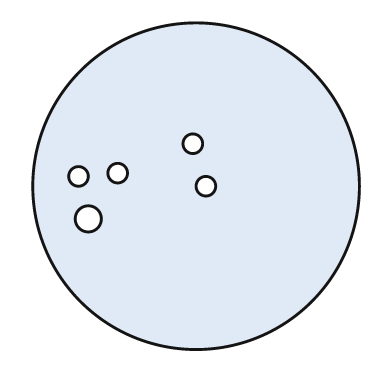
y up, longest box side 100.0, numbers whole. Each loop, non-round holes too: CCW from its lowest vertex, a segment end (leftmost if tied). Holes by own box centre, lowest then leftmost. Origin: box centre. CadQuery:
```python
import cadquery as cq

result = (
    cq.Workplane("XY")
    .moveTo(0.0, 0.0)
    .circle(50.0)
    .moveTo(-33.0, -10.0)
    .circle(4.0)
    .moveTo(3.0, 0.0)
    .circle(3.0)
    .moveTo(-36.0, 3.0)
    .circle(3.0)
    .moveTo(-24.0, 4.0)
    .circle(3.0)
    .moveTo(-1.0, 13.0)
    .circle(3.0)
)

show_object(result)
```